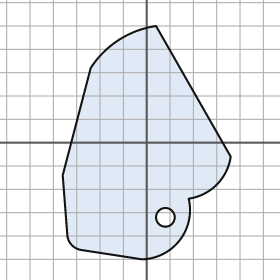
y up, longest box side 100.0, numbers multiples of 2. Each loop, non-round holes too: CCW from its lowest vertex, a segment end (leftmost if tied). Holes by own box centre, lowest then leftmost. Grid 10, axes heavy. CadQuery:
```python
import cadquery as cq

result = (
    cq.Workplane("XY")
    .moveTo(-2.0, -50.0)
    .threePointArc((14.0, -42.0), (18.0, -24.0))
    .threePointArc((30.0, -18.0), (36.0, -6.0))
    .lineTo(4.0, 50.0)
    .threePointArc((-12.0, 44.0), (-24.0, 32.0))
    .lineTo(-36.0, -14.0)
    .lineTo(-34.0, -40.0)
    .threePointArc((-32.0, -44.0), (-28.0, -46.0))
    .close()
    .moveTo(8.0, -32.0)
    .circle(4.0)
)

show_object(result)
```